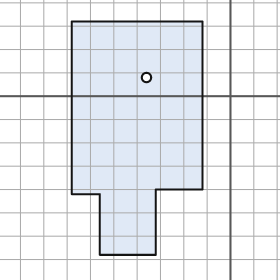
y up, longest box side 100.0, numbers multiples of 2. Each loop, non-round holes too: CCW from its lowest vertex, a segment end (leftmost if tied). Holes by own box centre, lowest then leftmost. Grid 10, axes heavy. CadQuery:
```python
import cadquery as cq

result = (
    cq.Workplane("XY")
    .moveTo(-56.0, -68.0)
    .lineTo(-32.0, -68.0)
    .lineTo(-32.0, -40.0)
    .lineTo(-12.0, -40.0)
    .lineTo(-12.0, 32.0)
    .lineTo(-68.0, 32.0)
    .lineTo(-68.0, -42.0)
    .lineTo(-56.0, -42.0)
    .close()
    .moveTo(-36.0, 8.0)
    .circle(2.0)
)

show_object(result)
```